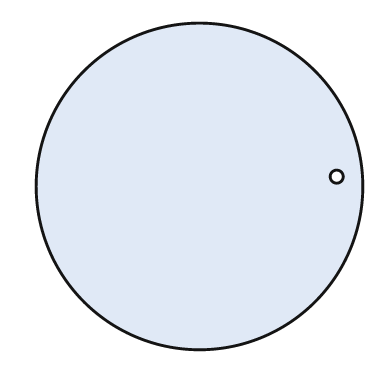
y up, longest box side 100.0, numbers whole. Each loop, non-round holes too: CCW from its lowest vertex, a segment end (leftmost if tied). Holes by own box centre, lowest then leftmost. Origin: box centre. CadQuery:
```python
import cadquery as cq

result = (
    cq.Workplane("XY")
    .moveTo(0.0, 0.0)
    .circle(50.0)
    .moveTo(42.0, 3.0)
    .circle(2.0)
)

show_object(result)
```